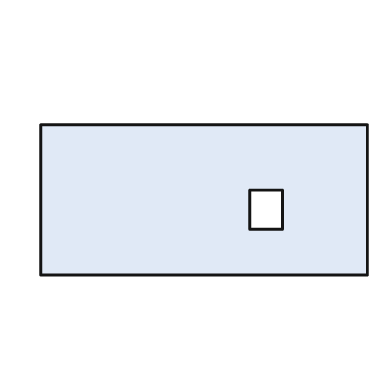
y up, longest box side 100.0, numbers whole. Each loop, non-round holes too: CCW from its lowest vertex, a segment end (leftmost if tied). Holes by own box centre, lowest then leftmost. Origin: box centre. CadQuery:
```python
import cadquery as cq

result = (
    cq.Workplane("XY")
    .moveTo(-50.0, -23.0)
    .lineTo(50.0, -23.0)
    .lineTo(50.0, 23.0)
    .lineTo(-50.0, 23.0)
    .close()
    .moveTo(14.0, -9.0)
    .lineTo(24.0, -9.0)
    .lineTo(24.0, 3.0)
    .lineTo(14.0, 3.0)
    .close()
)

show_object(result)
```